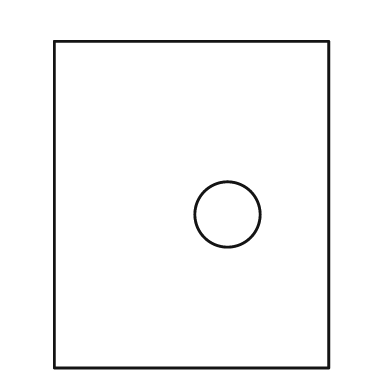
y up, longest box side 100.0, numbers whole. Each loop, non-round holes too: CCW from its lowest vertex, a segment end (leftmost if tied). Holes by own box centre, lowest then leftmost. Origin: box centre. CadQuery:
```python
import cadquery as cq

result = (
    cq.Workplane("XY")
    .moveTo(-42.0, -50.0)
    .lineTo(42.0, -50.0)
    .lineTo(42.0, 50.0)
    .lineTo(-42.0, 50.0)
    .close()
    .moveTo(11.0, -3.0)
    .circle(10.0)
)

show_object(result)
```